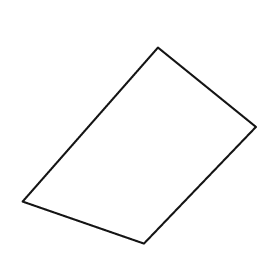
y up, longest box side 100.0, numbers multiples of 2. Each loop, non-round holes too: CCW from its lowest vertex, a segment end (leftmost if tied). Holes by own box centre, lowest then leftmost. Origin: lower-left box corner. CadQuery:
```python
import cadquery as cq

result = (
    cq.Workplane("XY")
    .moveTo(52.0, 0.0)
    .lineTo(100.0, 50.0)
    .lineTo(58.0, 84.0)
    .lineTo(0.0, 18.0)
    .close()
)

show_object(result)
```